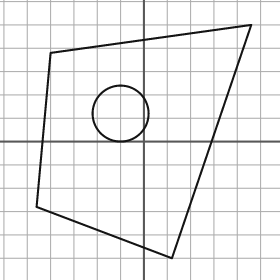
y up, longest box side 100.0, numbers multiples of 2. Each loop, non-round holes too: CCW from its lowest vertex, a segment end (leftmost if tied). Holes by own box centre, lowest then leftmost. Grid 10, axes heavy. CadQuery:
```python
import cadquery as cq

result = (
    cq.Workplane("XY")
    .moveTo(12.0, -50.0)
    .lineTo(46.0, 50.0)
    .lineTo(-40.0, 38.0)
    .lineTo(-46.0, -28.0)
    .close()
    .moveTo(-10.0, 12.0)
    .circle(12.0)
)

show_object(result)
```